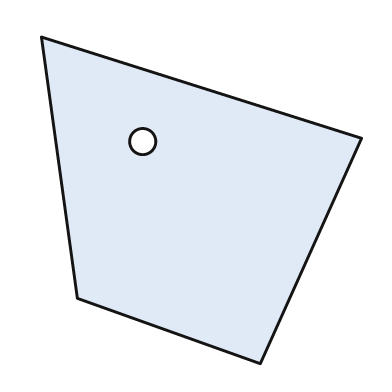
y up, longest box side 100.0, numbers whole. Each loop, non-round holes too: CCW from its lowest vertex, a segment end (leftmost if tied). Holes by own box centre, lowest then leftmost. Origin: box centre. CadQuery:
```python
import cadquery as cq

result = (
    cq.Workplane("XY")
    .moveTo(18.0, -50.0)
    .lineTo(49.0, 19.0)
    .lineTo(-49.0, 50.0)
    .lineTo(-38.0, -30.0)
    .close()
    .moveTo(-18.0, 18.0)
    .circle(4.0)
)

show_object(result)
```